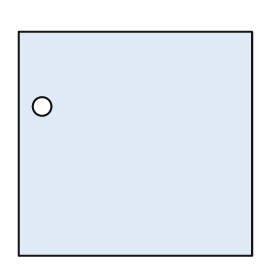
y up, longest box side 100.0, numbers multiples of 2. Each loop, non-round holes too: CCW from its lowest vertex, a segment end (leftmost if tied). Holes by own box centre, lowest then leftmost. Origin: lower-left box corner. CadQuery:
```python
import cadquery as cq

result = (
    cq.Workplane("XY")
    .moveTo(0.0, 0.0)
    .lineTo(100.0, 0.0)
    .lineTo(100.0, 96.0)
    .lineTo(0.0, 96.0)
    .close()
    .moveTo(10.0, 64.0)
    .circle(4.0)
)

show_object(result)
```